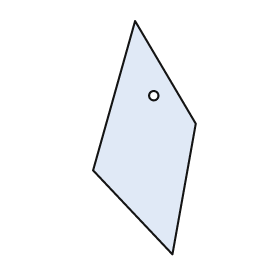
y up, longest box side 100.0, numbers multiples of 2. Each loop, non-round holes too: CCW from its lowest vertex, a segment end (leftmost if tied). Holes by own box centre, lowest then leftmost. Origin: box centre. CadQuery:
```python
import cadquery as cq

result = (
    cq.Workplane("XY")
    .moveTo(12.0, -50.0)
    .lineTo(22.0, 6.0)
    .lineTo(-4.0, 50.0)
    .lineTo(-22.0, -14.0)
    .close()
    .moveTo(4.0, 18.0)
    .circle(2.0)
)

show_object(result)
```